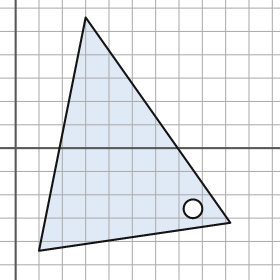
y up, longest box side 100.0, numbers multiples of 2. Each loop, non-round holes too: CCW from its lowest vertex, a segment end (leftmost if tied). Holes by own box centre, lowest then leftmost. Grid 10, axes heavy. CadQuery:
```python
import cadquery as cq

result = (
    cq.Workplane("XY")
    .moveTo(10.0, -44.0)
    .lineTo(92.0, -32.0)
    .lineTo(30.0, 56.0)
    .close()
    .moveTo(76.0, -26.0)
    .circle(4.0)
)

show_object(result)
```